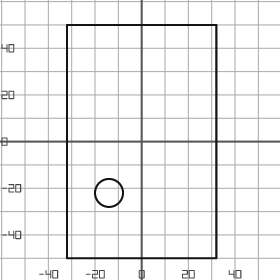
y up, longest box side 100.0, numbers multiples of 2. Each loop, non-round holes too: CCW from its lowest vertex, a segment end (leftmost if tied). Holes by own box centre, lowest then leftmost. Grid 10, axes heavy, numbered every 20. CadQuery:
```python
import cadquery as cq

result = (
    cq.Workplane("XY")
    .moveTo(-32.0, -50.0)
    .lineTo(32.0, -50.0)
    .lineTo(32.0, 50.0)
    .lineTo(-32.0, 50.0)
    .close()
    .moveTo(-14.0, -22.0)
    .circle(6.0)
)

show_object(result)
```